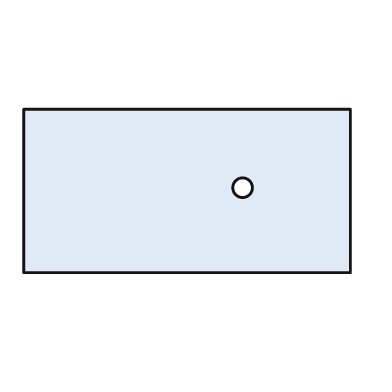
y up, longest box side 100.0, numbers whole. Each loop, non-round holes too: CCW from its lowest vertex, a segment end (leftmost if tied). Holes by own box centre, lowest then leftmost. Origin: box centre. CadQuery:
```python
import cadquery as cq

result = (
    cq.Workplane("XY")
    .moveTo(-50.0, -25.0)
    .lineTo(50.0, -25.0)
    .lineTo(50.0, 25.0)
    .lineTo(-50.0, 25.0)
    .close()
    .moveTo(17.0, 1.0)
    .circle(3.0)
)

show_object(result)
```